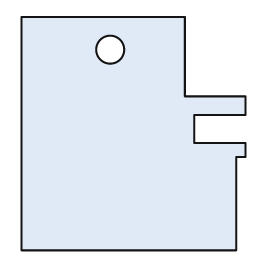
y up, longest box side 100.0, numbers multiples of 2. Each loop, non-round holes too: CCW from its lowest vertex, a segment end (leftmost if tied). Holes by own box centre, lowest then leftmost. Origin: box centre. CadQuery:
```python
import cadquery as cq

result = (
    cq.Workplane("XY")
    .moveTo(-48.0, -50.0)
    .lineTo(44.0, -50.0)
    .lineTo(44.0, -10.0)
    .lineTo(48.0, -10.0)
    .lineTo(48.0, -4.0)
    .lineTo(26.0, -4.0)
    .lineTo(26.0, 8.0)
    .lineTo(48.0, 8.0)
    .lineTo(48.0, 16.0)
    .lineTo(22.0, 16.0)
    .lineTo(22.0, 50.0)
    .lineTo(-48.0, 50.0)
    .close()
    .moveTo(-10.0, 36.0)
    .circle(6.0)
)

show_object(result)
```